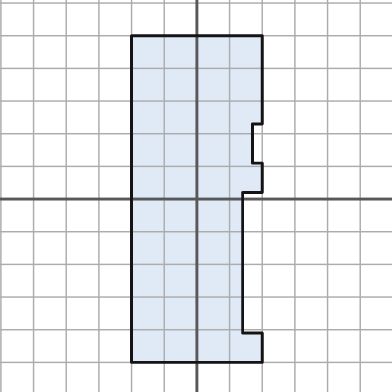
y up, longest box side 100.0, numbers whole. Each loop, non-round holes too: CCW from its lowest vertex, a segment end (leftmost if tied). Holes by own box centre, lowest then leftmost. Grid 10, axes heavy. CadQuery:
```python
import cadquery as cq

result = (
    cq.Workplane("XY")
    .moveTo(-20.0, -50.0)
    .lineTo(20.0, -50.0)
    .lineTo(20.0, -41.0)
    .lineTo(14.0, -41.0)
    .lineTo(14.0, 2.0)
    .lineTo(20.0, 2.0)
    .lineTo(20.0, 11.0)
    .lineTo(17.0, 11.0)
    .lineTo(17.0, 23.0)
    .lineTo(20.0, 23.0)
    .lineTo(20.0, 50.0)
    .lineTo(-20.0, 50.0)
    .close()
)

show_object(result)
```